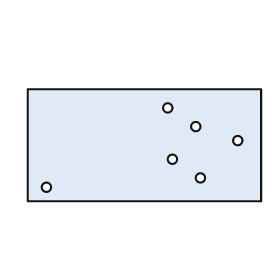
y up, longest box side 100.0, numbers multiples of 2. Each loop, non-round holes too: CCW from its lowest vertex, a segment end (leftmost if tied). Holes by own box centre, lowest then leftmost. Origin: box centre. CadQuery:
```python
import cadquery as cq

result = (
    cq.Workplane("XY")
    .moveTo(-50.0, -24.0)
    .lineTo(50.0, -24.0)
    .lineTo(50.0, 24.0)
    .lineTo(-50.0, 24.0)
    .close()
    .moveTo(-42.0, -18.0)
    .circle(2.0)
    .moveTo(24.0, -14.0)
    .circle(2.0)
    .moveTo(12.0, -6.0)
    .circle(2.0)
    .moveTo(40.0, 2.0)
    .circle(2.0)
    .moveTo(22.0, 8.0)
    .circle(2.0)
    .moveTo(10.0, 16.0)
    .circle(2.0)
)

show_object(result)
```